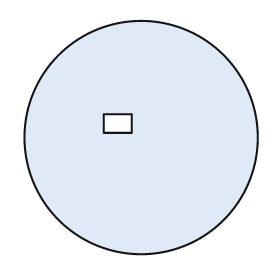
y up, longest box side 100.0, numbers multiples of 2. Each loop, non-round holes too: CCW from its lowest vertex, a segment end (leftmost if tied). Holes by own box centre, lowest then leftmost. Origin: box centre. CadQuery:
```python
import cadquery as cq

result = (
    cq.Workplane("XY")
    .moveTo(0.0, 0.0)
    .circle(50.0)
    .moveTo(-16.0, 2.0)
    .lineTo(-4.0, 2.0)
    .lineTo(-4.0, 10.0)
    .lineTo(-16.0, 10.0)
    .close()
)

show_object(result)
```